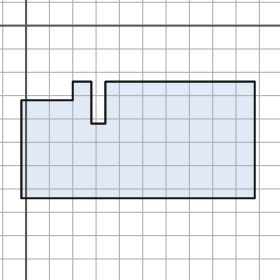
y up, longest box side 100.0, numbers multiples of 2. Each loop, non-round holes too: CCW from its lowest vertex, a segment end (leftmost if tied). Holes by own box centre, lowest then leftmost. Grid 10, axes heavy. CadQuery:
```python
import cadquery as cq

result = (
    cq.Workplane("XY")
    .moveTo(-2.0, -74.0)
    .lineTo(98.0, -74.0)
    .lineTo(98.0, -24.0)
    .lineTo(34.0, -24.0)
    .lineTo(34.0, -42.0)
    .lineTo(28.0, -42.0)
    .lineTo(28.0, -24.0)
    .lineTo(20.0, -24.0)
    .lineTo(20.0, -32.0)
    .lineTo(-2.0, -32.0)
    .close()
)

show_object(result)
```